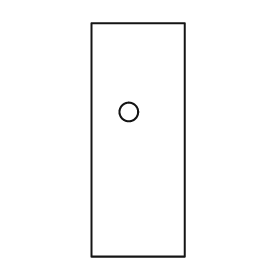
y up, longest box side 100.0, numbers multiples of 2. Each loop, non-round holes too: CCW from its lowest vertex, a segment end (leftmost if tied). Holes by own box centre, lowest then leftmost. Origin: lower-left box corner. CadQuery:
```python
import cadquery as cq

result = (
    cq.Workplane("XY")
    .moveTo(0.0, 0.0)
    .lineTo(40.0, 0.0)
    .lineTo(40.0, 100.0)
    .lineTo(0.0, 100.0)
    .close()
    .moveTo(16.0, 62.0)
    .circle(4.0)
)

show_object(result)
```